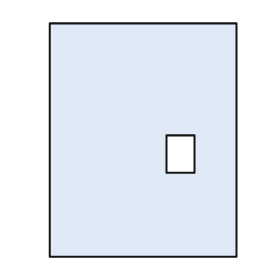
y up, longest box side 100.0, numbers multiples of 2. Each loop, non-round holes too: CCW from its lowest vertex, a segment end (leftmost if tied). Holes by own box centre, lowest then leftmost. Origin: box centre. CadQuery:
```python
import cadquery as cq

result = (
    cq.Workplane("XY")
    .moveTo(-40.0, -50.0)
    .lineTo(40.0, -50.0)
    .lineTo(40.0, 50.0)
    .lineTo(-40.0, 50.0)
    .close()
    .moveTo(10.0, -14.0)
    .lineTo(22.0, -14.0)
    .lineTo(22.0, 2.0)
    .lineTo(10.0, 2.0)
    .close()
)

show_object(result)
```